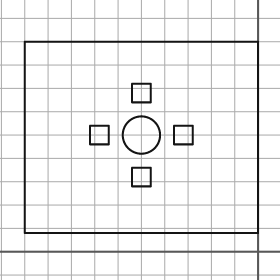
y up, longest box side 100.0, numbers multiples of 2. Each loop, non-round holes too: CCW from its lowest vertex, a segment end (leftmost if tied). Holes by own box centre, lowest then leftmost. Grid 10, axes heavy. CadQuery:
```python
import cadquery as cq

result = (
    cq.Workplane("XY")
    .moveTo(-100.0, 8.0)
    .lineTo(0.0, 8.0)
    .lineTo(0.0, 90.0)
    .lineTo(-100.0, 90.0)
    .close()
    .moveTo(-54.0, 28.0)
    .lineTo(-46.0, 28.0)
    .lineTo(-46.0, 36.0)
    .lineTo(-54.0, 36.0)
    .close()
    .moveTo(-72.0, 46.0)
    .lineTo(-64.0, 46.0)
    .lineTo(-64.0, 54.0)
    .lineTo(-72.0, 54.0)
    .close()
    .moveTo(-50.0, 50.0)
    .circle(8.0)
    .moveTo(-36.0, 46.0)
    .lineTo(-28.0, 46.0)
    .lineTo(-28.0, 54.0)
    .lineTo(-36.0, 54.0)
    .close()
    .moveTo(-54.0, 64.0)
    .lineTo(-46.0, 64.0)
    .lineTo(-46.0, 72.0)
    .lineTo(-54.0, 72.0)
    .close()
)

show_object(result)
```